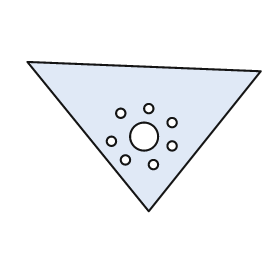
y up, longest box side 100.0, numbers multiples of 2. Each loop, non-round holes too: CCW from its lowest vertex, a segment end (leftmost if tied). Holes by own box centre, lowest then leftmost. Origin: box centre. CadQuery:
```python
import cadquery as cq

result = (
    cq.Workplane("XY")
    .moveTo(2.0, -32.0)
    .lineTo(50.0, 28.0)
    .lineTo(-50.0, 32.0)
    .close()
    .moveTo(4.0, -12.0)
    .circle(2.0)
    .moveTo(-8.0, -10.0)
    .circle(2.0)
    .moveTo(12.0, -4.0)
    .circle(2.0)
    .moveTo(-14.0, -2.0)
    .circle(2.0)
    .moveTo(0.0, 0.0)
    .circle(6.0)
    .moveTo(12.0, 6.0)
    .circle(2.0)
    .moveTo(-10.0, 10.0)
    .circle(2.0)
    .moveTo(2.0, 12.0)
    .circle(2.0)
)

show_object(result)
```